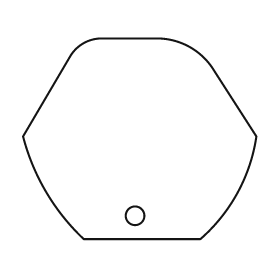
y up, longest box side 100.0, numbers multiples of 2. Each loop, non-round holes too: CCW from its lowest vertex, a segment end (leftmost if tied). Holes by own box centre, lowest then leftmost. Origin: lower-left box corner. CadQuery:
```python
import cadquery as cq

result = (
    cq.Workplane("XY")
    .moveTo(26.0, 0.0)
    .lineTo(76.0, 0.0)
    .threePointArc((92.0, 20.0), (100.0, 44.0))
    .lineTo(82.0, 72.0)
    .threePointArc((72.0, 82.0), (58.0, 86.0))
    .lineTo(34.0, 86.0)
    .threePointArc((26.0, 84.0), (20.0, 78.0))
    .lineTo(0.0, 44.0)
    .threePointArc((10.0, 20.0), (26.0, 0.0))
    .close()
    .moveTo(48.0, 10.0)
    .circle(4.0)
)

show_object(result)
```